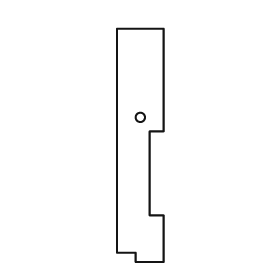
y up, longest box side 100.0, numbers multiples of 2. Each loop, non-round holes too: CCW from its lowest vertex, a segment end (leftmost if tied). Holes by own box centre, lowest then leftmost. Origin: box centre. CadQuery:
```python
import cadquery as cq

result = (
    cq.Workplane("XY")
    .moveTo(-2.0, -50.0)
    .lineTo(10.0, -50.0)
    .lineTo(10.0, -30.0)
    .lineTo(4.0, -30.0)
    .lineTo(4.0, 6.0)
    .lineTo(10.0, 6.0)
    .lineTo(10.0, 50.0)
    .lineTo(-10.0, 50.0)
    .lineTo(-10.0, -46.0)
    .lineTo(-2.0, -46.0)
    .close()
    .moveTo(0.0, 12.0)
    .circle(2.0)
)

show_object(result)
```